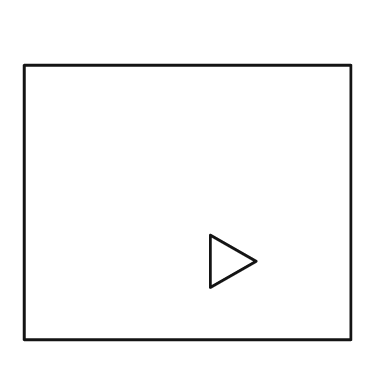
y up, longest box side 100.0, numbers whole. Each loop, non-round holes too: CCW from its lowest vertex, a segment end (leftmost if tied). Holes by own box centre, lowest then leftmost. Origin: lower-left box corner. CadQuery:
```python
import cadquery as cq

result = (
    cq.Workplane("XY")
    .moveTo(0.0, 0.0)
    .lineTo(100.0, 0.0)
    .lineTo(100.0, 84.0)
    .lineTo(0.0, 84.0)
    .close()
    .moveTo(57.0, 16.0)
    .lineTo(71.0, 24.0)
    .lineTo(57.0, 32.0)
    .close()
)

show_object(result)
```